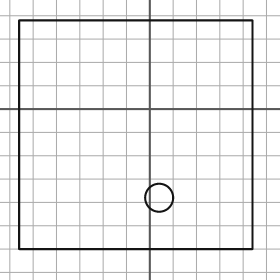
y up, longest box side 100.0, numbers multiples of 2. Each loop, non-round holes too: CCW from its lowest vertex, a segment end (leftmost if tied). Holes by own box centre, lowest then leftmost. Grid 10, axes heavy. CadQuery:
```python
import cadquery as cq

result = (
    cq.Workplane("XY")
    .moveTo(-56.0, -60.0)
    .lineTo(44.0, -60.0)
    .lineTo(44.0, 38.0)
    .lineTo(-56.0, 38.0)
    .close()
    .moveTo(4.0, -38.0)
    .circle(6.0)
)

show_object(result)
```